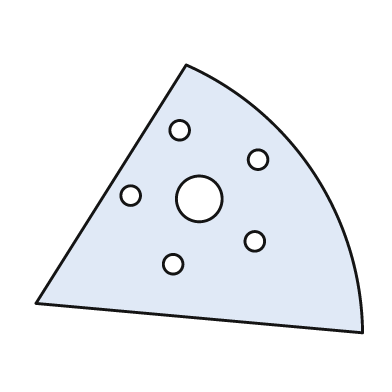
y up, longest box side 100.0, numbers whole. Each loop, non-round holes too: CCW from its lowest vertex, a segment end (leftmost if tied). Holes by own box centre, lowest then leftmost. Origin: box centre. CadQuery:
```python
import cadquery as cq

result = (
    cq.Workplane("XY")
    .moveTo(50.0, -41.0)
    .threePointArc((35.0, 8.0), (-4.0, 41.0))
    .lineTo(-50.0, -32.0)
    .close()
    .moveTo(-8.0, -20.0)
    .circle(3.0)
    .moveTo(17.0, -13.0)
    .circle(3.0)
    .moveTo(0.0, 0.0)
    .circle(7.0)
    .moveTo(-21.0, 1.0)
    .circle(3.0)
    .moveTo(18.0, 12.0)
    .circle(3.0)
    .moveTo(-6.0, 21.0)
    .circle(3.0)
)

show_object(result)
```